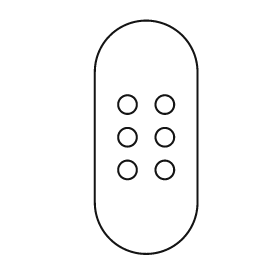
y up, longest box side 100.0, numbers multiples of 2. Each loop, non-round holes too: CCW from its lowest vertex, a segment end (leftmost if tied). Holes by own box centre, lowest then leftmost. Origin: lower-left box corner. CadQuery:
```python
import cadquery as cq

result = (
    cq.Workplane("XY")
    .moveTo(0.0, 22.0)
    .threePointArc((22.0, 0.0), (44.0, 22.0))
    .lineTo(44.0, 78.0)
    .threePointArc((22.0, 100.0), (0.0, 78.0))
    .close()
    .moveTo(14.0, 36.0)
    .circle(4.0)
    .moveTo(30.0, 36.0)
    .circle(4.0)
    .moveTo(14.0, 50.0)
    .circle(4.0)
    .moveTo(30.0, 50.0)
    .circle(4.0)
    .moveTo(14.0, 64.0)
    .circle(4.0)
    .moveTo(30.0, 64.0)
    .circle(4.0)
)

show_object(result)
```